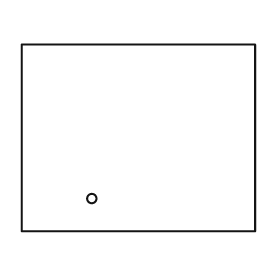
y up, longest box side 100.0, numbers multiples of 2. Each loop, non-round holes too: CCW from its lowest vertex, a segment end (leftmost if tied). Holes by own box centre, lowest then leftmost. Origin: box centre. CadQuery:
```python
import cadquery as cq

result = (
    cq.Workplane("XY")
    .moveTo(-50.0, -40.0)
    .lineTo(50.0, -40.0)
    .lineTo(50.0, 40.0)
    .lineTo(-50.0, 40.0)
    .close()
    .moveTo(-20.0, -26.0)
    .circle(2.0)
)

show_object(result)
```